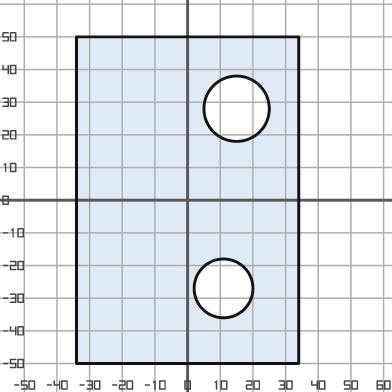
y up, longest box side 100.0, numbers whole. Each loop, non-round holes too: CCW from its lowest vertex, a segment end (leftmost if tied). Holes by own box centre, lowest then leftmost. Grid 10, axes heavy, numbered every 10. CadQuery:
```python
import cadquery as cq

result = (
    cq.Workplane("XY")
    .moveTo(-34.0, -50.0)
    .lineTo(34.0, -50.0)
    .lineTo(34.0, 50.0)
    .lineTo(-34.0, 50.0)
    .close()
    .moveTo(11.0, -27.0)
    .circle(9.0)
    .moveTo(15.0, 28.0)
    .circle(10.0)
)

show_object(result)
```